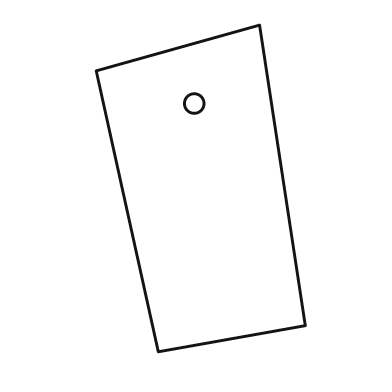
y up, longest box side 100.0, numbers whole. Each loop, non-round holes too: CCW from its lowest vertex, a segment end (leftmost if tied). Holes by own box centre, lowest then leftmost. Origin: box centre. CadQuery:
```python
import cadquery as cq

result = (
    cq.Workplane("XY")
    .moveTo(-13.0, -50.0)
    .lineTo(32.0, -42.0)
    .lineTo(18.0, 50.0)
    .lineTo(-32.0, 36.0)
    .close()
    .moveTo(-2.0, 26.0)
    .circle(3.0)
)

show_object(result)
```